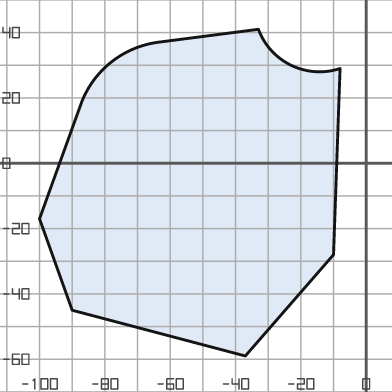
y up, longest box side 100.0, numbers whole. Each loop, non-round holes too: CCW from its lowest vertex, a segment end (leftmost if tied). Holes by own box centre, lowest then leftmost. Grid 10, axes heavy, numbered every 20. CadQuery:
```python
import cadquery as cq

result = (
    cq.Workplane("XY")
    .moveTo(-37.0, -59.0)
    .lineTo(-10.0, -28.0)
    .lineTo(-8.0, 29.0)
    .threePointArc((-23.0, 30.0), (-33.0, 41.0))
    .lineTo(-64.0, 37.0)
    .threePointArc((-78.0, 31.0), (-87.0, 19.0))
    .lineTo(-100.0, -17.0)
    .lineTo(-90.0, -45.0)
    .close()
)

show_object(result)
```